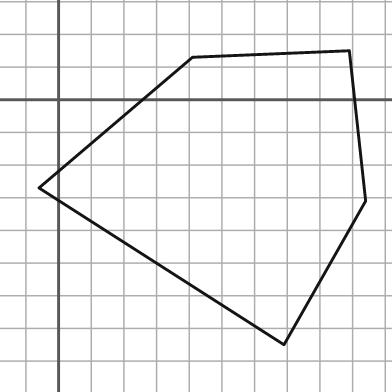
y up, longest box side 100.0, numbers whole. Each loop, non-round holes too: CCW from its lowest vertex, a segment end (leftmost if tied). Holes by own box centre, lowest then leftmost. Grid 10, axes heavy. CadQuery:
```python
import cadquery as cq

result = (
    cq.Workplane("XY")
    .moveTo(69.0, -75.0)
    .lineTo(94.0, -31.0)
    .lineTo(89.0, 15.0)
    .lineTo(41.0, 13.0)
    .lineTo(-6.0, -27.0)
    .close()
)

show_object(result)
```